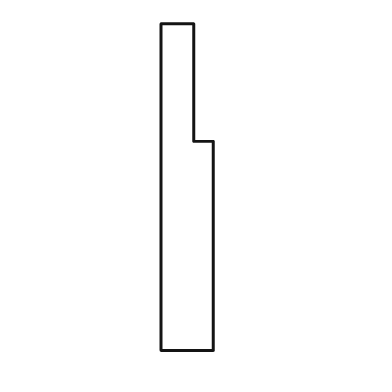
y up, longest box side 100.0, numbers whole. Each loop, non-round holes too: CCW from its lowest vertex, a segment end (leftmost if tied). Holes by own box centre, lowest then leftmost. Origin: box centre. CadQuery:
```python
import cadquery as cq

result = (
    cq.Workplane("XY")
    .moveTo(-8.0, -50.0)
    .lineTo(8.0, -50.0)
    .lineTo(8.0, 14.0)
    .lineTo(2.0, 14.0)
    .lineTo(2.0, 50.0)
    .lineTo(-8.0, 50.0)
    .close()
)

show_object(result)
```